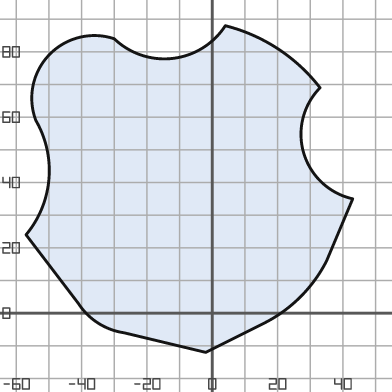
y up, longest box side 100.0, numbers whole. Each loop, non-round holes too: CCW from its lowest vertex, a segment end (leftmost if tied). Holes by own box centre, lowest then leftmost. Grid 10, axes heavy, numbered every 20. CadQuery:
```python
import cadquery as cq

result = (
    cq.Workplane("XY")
    .moveTo(-2.0, -12.0)
    .lineTo(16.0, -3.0)
    .threePointArc((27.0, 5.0), (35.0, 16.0))
    .lineTo(43.0, 35.0)
    .threePointArc((28.0, 49.0), (33.0, 69.0))
    .threePointArc((20.0, 81.0), (4.0, 88.0))
    .threePointArc((-12.0, 78.0), (-30.0, 84.0))
    .threePointArc((-50.0, 79.0), (-54.0, 59.0))
    .threePointArc((-50.0, 41.0), (-57.0, 24.0))
    .lineTo(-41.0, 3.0)
    .threePointArc((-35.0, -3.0), (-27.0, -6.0))
    .close()
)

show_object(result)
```